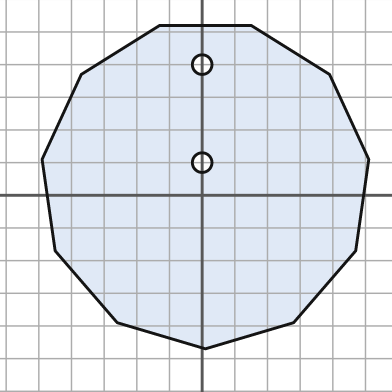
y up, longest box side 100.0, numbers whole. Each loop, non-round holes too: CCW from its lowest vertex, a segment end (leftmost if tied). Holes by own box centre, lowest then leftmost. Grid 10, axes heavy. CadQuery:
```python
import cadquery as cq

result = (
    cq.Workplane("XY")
    .moveTo(1.0, -47.0)
    .lineTo(28.0, -39.0)
    .lineTo(47.0, -17.0)
    .lineTo(51.0, 11.0)
    .lineTo(39.0, 37.0)
    .lineTo(15.0, 52.0)
    .lineTo(-13.0, 52.0)
    .lineTo(-37.0, 37.0)
    .lineTo(-49.0, 11.0)
    .lineTo(-45.0, -17.0)
    .lineTo(-26.0, -39.0)
    .close()
    .moveTo(0.0, 10.0)
    .circle(3.0)
    .moveTo(0.0, 40.0)
    .circle(3.0)
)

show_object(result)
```